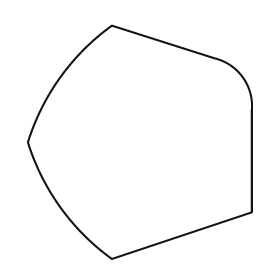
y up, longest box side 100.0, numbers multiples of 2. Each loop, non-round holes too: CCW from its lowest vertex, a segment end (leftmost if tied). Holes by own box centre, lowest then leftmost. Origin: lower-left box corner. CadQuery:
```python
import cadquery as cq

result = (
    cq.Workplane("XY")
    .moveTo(36.0, 0.0)
    .lineTo(96.0, 20.0)
    .lineTo(96.0, 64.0)
    .threePointArc((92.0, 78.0), (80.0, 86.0))
    .lineTo(36.0, 100.0)
    .threePointArc((14.0, 78.0), (0.0, 50.0))
    .threePointArc((14.0, 22.0), (36.0, 0.0))
    .close()
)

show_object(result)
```